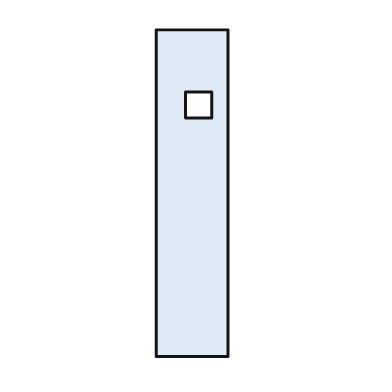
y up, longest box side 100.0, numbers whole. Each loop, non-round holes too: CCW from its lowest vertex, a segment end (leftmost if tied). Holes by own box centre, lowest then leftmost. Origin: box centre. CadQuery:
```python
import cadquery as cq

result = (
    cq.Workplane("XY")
    .moveTo(-11.0, -50.0)
    .lineTo(11.0, -50.0)
    .lineTo(11.0, 50.0)
    .lineTo(-11.0, 50.0)
    .close()
    .moveTo(-2.0, 23.0)
    .lineTo(6.0, 23.0)
    .lineTo(6.0, 31.0)
    .lineTo(-2.0, 31.0)
    .close()
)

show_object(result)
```